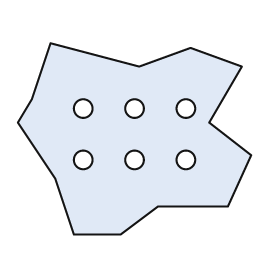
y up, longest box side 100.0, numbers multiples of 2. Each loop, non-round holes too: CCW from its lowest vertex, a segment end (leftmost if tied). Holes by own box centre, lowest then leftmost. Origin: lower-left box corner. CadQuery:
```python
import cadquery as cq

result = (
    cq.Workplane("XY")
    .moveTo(24.0, 0.0)
    .lineTo(44.0, 0.0)
    .lineTo(60.0, 12.0)
    .lineTo(90.0, 12.0)
    .lineTo(100.0, 34.0)
    .lineTo(82.0, 48.0)
    .lineTo(96.0, 72.0)
    .lineTo(74.0, 80.0)
    .lineTo(52.0, 72.0)
    .lineTo(14.0, 82.0)
    .lineTo(6.0, 58.0)
    .lineTo(0.0, 48.0)
    .lineTo(16.0, 24.0)
    .close()
    .moveTo(28.0, 32.0)
    .circle(4.0)
    .moveTo(50.0, 32.0)
    .circle(4.0)
    .moveTo(72.0, 32.0)
    .circle(4.0)
    .moveTo(28.0, 54.0)
    .circle(4.0)
    .moveTo(50.0, 54.0)
    .circle(4.0)
    .moveTo(72.0, 54.0)
    .circle(4.0)
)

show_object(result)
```